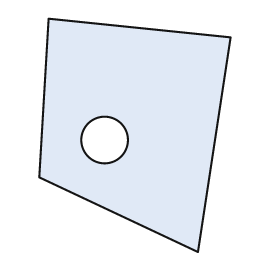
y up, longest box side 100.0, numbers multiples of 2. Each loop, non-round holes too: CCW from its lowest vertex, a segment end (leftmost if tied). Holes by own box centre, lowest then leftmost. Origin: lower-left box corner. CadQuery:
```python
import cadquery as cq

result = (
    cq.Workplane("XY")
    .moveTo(68.0, 0.0)
    .lineTo(82.0, 92.0)
    .lineTo(4.0, 100.0)
    .lineTo(0.0, 32.0)
    .close()
    .moveTo(28.0, 48.0)
    .circle(10.0)
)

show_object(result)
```